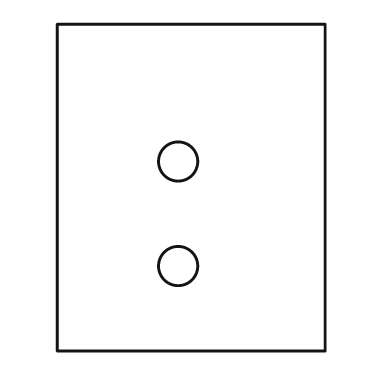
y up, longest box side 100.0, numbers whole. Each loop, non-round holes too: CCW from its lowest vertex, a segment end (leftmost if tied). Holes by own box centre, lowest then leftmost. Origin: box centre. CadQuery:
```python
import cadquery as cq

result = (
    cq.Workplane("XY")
    .moveTo(-41.0, -50.0)
    .lineTo(41.0, -50.0)
    .lineTo(41.0, 50.0)
    .lineTo(-41.0, 50.0)
    .close()
    .moveTo(-4.0, -24.0)
    .circle(6.0)
    .moveTo(-4.0, 8.0)
    .circle(6.0)
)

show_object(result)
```